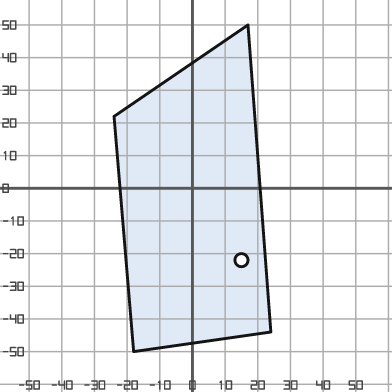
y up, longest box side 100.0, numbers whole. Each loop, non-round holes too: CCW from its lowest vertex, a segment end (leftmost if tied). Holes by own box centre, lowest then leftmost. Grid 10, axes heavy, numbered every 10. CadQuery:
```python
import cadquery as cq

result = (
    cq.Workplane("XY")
    .moveTo(-18.0, -50.0)
    .lineTo(24.0, -44.0)
    .lineTo(17.0, 50.0)
    .lineTo(-24.0, 22.0)
    .close()
    .moveTo(15.0, -22.0)
    .circle(2.0)
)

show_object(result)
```